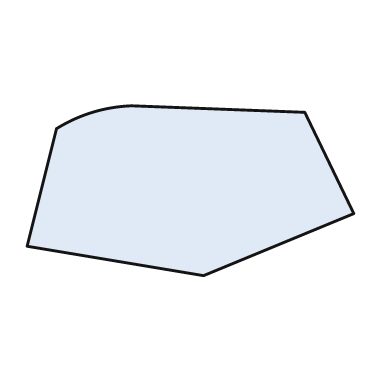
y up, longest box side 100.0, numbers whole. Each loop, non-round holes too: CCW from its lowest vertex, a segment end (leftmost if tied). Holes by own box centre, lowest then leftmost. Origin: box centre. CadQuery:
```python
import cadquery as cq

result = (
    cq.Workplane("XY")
    .moveTo(4.0, -26.0)
    .lineTo(50.0, -7.0)
    .lineTo(35.0, 24.0)
    .lineTo(-18.0, 26.0)
    .threePointArc((-30.0, 24.0), (-41.0, 19.0))
    .lineTo(-50.0, -17.0)
    .close()
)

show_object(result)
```